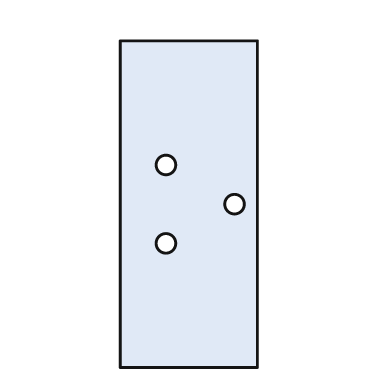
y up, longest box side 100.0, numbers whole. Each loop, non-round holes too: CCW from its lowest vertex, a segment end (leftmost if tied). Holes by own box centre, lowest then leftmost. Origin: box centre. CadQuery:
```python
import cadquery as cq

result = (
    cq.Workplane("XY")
    .moveTo(-21.0, -50.0)
    .lineTo(21.0, -50.0)
    .lineTo(21.0, 50.0)
    .lineTo(-21.0, 50.0)
    .close()
    .moveTo(-7.0, -12.0)
    .circle(3.0)
    .moveTo(14.0, 0.0)
    .circle(3.0)
    .moveTo(-7.0, 12.0)
    .circle(3.0)
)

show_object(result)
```